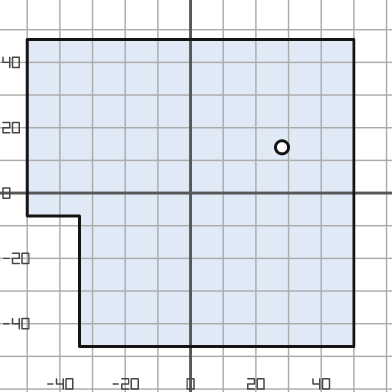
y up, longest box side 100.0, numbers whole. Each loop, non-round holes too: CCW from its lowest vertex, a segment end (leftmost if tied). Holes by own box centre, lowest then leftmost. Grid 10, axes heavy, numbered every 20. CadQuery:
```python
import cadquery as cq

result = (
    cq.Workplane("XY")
    .moveTo(-34.0, -47.0)
    .lineTo(50.0, -47.0)
    .lineTo(50.0, 47.0)
    .lineTo(-50.0, 47.0)
    .lineTo(-50.0, -7.0)
    .lineTo(-34.0, -7.0)
    .close()
    .moveTo(28.0, 14.0)
    .circle(2.0)
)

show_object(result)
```